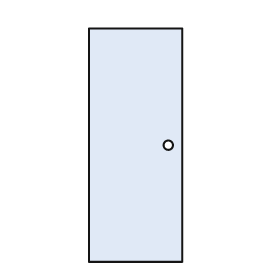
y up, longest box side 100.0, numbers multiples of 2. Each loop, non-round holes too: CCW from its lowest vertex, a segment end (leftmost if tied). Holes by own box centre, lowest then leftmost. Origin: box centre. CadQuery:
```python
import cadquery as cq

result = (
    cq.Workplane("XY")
    .moveTo(-20.0, -50.0)
    .lineTo(20.0, -50.0)
    .lineTo(20.0, 50.0)
    .lineTo(-20.0, 50.0)
    .close()
    .moveTo(14.0, 0.0)
    .circle(2.0)
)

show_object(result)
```